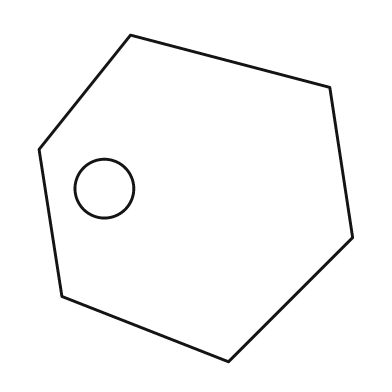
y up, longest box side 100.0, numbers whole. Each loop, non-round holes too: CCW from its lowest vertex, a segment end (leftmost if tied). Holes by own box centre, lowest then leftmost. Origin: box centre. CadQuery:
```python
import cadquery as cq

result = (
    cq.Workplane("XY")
    .moveTo(10.0, -50.0)
    .lineTo(48.0, -12.0)
    .lineTo(41.0, 34.0)
    .lineTo(-20.0, 50.0)
    .lineTo(-48.0, 15.0)
    .lineTo(-41.0, -30.0)
    .close()
    .moveTo(-28.0, 3.0)
    .circle(9.0)
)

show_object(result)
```